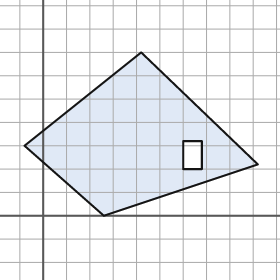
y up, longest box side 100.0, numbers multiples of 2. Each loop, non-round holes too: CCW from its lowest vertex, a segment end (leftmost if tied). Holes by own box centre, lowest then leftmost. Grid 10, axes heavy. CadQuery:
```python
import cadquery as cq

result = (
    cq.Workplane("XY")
    .moveTo(26.0, 0.0)
    .lineTo(92.0, 22.0)
    .lineTo(42.0, 70.0)
    .lineTo(-8.0, 30.0)
    .close()
    .moveTo(60.0, 20.0)
    .lineTo(68.0, 20.0)
    .lineTo(68.0, 32.0)
    .lineTo(60.0, 32.0)
    .close()
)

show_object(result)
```